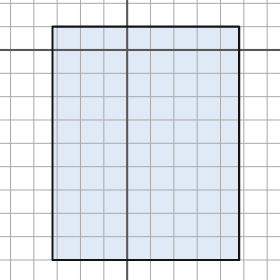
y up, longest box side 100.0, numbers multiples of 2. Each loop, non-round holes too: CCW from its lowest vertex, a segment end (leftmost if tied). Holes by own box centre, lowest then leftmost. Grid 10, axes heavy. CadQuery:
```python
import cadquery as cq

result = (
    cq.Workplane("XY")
    .moveTo(-32.0, -90.0)
    .lineTo(48.0, -90.0)
    .lineTo(48.0, 10.0)
    .lineTo(-32.0, 10.0)
    .close()
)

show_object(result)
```